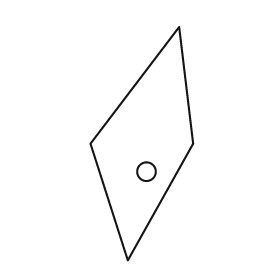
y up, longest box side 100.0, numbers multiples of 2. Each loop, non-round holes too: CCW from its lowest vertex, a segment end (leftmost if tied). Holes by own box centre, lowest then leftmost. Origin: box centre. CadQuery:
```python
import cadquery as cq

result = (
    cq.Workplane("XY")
    .moveTo(-6.0, -50.0)
    .lineTo(22.0, 0.0)
    .lineTo(16.0, 50.0)
    .lineTo(-22.0, 0.0)
    .close()
    .moveTo(2.0, -12.0)
    .circle(4.0)
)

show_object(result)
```